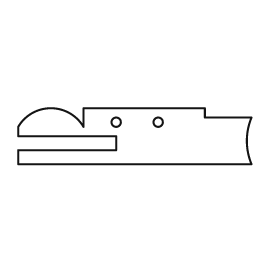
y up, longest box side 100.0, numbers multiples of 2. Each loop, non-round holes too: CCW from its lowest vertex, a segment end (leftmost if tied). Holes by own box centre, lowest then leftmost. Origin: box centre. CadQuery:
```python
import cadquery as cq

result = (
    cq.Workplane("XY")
    .moveTo(-50.0, -12.0)
    .lineTo(50.0, -12.0)
    .threePointArc((48.0, -2.0), (50.0, 8.0))
    .lineTo(30.0, 8.0)
    .lineTo(30.0, 12.0)
    .lineTo(-22.0, 12.0)
    .lineTo(-22.0, 4.0)
    .threePointArc((-36.0, 12.0), (-50.0, 4.0))
    .lineTo(-50.0, 0.0)
    .lineTo(-8.0, 0.0)
    .lineTo(-8.0, -6.0)
    .lineTo(-50.0, -6.0)
    .close()
    .moveTo(-8.0, 6.0)
    .circle(2.0)
    .moveTo(10.0, 6.0)
    .circle(2.0)
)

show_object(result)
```